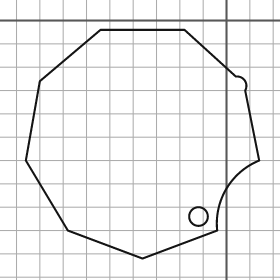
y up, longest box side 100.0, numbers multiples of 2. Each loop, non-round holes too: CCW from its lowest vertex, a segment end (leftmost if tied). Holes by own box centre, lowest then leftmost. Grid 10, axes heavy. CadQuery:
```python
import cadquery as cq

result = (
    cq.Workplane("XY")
    .moveTo(-36.0, -102.0)
    .lineTo(-4.0, -90.0)
    .threePointArc((0.0, -72.0), (14.0, -60.0))
    .lineTo(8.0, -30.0)
    .threePointArc((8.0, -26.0), (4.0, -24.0))
    .lineTo(-18.0, -4.0)
    .lineTo(-54.0, -4.0)
    .lineTo(-80.0, -26.0)
    .lineTo(-86.0, -60.0)
    .lineTo(-68.0, -90.0)
    .close()
    .moveTo(-12.0, -84.0)
    .circle(4.0)
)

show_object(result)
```